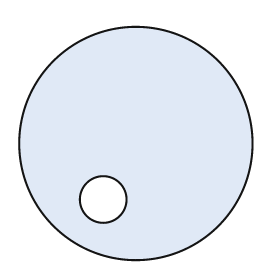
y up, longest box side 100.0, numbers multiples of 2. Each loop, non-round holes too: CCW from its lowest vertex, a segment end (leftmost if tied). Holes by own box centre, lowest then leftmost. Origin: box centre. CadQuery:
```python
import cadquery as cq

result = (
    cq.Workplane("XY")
    .moveTo(0.0, 0.0)
    .circle(50.0)
    .moveTo(-14.0, -24.0)
    .circle(10.0)
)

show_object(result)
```